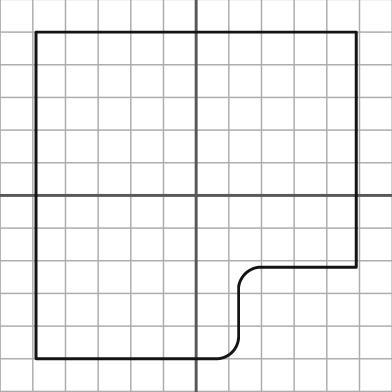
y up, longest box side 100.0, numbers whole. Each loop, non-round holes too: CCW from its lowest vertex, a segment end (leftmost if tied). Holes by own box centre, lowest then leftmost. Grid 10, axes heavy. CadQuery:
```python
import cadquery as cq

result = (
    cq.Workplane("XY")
    .moveTo(-49.0, -50.0)
    .lineTo(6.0, -50.0)
    .threePointArc((11.0, -48.0), (13.0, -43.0))
    .lineTo(13.0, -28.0)
    .threePointArc((15.0, -24.0), (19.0, -22.0))
    .lineTo(49.0, -22.0)
    .lineTo(49.0, 50.0)
    .lineTo(-49.0, 50.0)
    .close()
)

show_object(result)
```